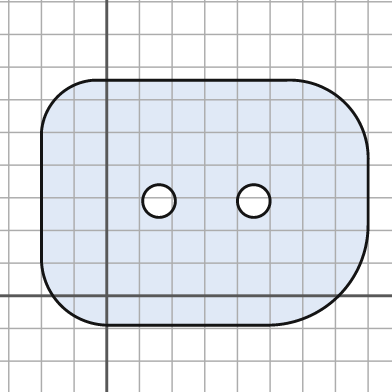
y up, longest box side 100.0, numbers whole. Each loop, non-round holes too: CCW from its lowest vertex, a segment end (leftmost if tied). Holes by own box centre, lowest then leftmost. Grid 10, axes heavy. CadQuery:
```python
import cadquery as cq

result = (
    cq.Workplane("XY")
    .moveTo(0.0, -9.0)
    .lineTo(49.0, -9.0)
    .threePointArc((71.0, 0.0), (80.0, 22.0))
    .lineTo(80.0, 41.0)
    .threePointArc((73.0, 59.0), (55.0, 66.0))
    .lineTo(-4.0, 66.0)
    .threePointArc((-15.0, 61.0), (-20.0, 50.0))
    .lineTo(-20.0, 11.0)
    .threePointArc((-14.0, -3.0), (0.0, -9.0))
    .close()
    .moveTo(16.0, 29.0)
    .circle(5.0)
    .moveTo(45.0, 29.0)
    .circle(5.0)
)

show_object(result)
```